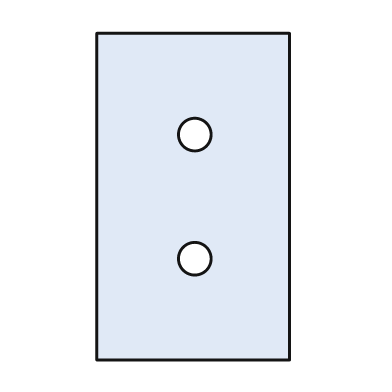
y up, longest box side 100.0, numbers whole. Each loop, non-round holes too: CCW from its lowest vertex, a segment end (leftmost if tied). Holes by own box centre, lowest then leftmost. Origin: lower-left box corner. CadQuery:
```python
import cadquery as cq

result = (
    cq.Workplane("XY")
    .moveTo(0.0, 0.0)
    .lineTo(59.0, 0.0)
    .lineTo(59.0, 100.0)
    .lineTo(0.0, 100.0)
    .close()
    .moveTo(30.0, 31.0)
    .circle(5.0)
    .moveTo(30.0, 69.0)
    .circle(5.0)
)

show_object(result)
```